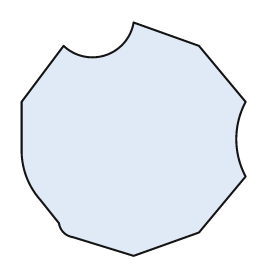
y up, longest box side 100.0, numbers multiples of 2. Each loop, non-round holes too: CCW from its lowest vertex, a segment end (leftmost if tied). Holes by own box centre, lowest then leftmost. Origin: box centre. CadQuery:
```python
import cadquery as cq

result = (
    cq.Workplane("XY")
    .moveTo(0.0, -50.0)
    .lineTo(28.0, -40.0)
    .lineTo(48.0, -16.0)
    .threePointArc((44.0, 0.0), (48.0, 16.0))
    .lineTo(28.0, 40.0)
    .lineTo(0.0, 50.0)
    .threePointArc((-12.0, 36.0), (-30.0, 40.0))
    .lineTo(-48.0, 16.0)
    .lineTo(-48.0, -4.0)
    .threePointArc((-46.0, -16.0), (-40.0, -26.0))
    .lineTo(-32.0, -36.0)
    .threePointArc((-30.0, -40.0), (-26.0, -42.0))
    .close()
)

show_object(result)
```